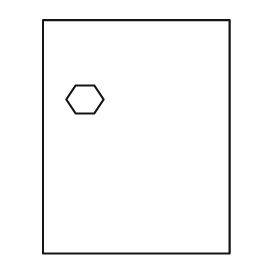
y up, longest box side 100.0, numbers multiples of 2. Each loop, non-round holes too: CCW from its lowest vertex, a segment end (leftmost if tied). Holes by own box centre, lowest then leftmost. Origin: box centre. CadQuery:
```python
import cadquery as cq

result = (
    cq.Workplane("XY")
    .moveTo(-40.0, -50.0)
    .lineTo(40.0, -50.0)
    .lineTo(40.0, 50.0)
    .lineTo(-40.0, 50.0)
    .close()
    .moveTo(-26.0, 10.0)
    .lineTo(-18.0, 10.0)
    .lineTo(-14.0, 16.0)
    .lineTo(-18.0, 22.0)
    .lineTo(-26.0, 22.0)
    .lineTo(-30.0, 16.0)
    .close()
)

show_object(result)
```